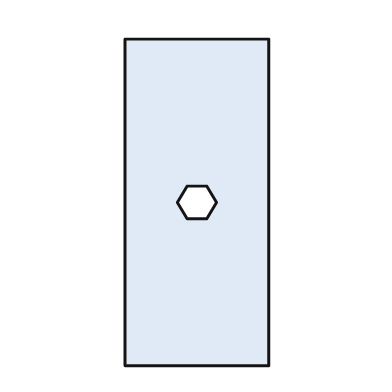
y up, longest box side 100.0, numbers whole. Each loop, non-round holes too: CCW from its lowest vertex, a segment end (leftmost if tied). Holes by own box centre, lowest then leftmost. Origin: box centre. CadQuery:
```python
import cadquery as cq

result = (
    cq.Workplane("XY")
    .moveTo(-22.0, -50.0)
    .lineTo(22.0, -50.0)
    .lineTo(22.0, 50.0)
    .lineTo(-22.0, 50.0)
    .close()
    .moveTo(-3.0, -5.0)
    .lineTo(3.0, -5.0)
    .lineTo(6.0, 0.0)
    .lineTo(3.0, 5.0)
    .lineTo(-3.0, 5.0)
    .lineTo(-6.0, 0.0)
    .close()
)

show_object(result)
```